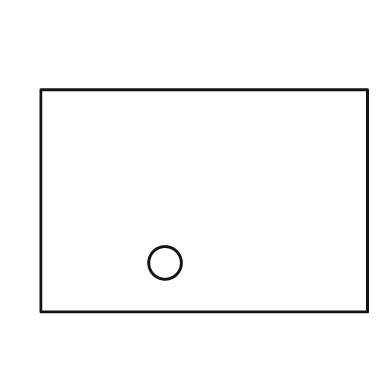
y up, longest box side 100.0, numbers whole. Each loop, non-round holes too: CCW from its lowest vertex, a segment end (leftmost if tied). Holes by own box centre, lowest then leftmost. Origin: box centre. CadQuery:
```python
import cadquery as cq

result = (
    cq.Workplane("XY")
    .moveTo(-50.0, -34.0)
    .lineTo(50.0, -34.0)
    .lineTo(50.0, 34.0)
    .lineTo(-50.0, 34.0)
    .close()
    .moveTo(-12.0, -19.0)
    .circle(5.0)
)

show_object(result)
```